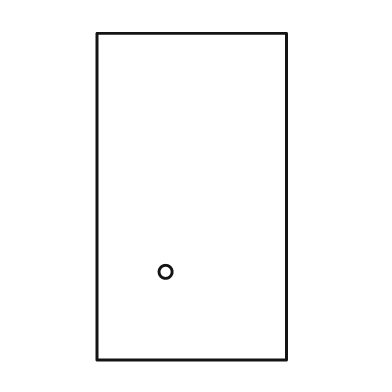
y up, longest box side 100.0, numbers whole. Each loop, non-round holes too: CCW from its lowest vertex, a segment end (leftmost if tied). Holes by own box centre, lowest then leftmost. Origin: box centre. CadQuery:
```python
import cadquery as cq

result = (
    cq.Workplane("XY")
    .moveTo(-29.0, -50.0)
    .lineTo(29.0, -50.0)
    .lineTo(29.0, 50.0)
    .lineTo(-29.0, 50.0)
    .close()
    .moveTo(-8.0, -23.0)
    .circle(2.0)
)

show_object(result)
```